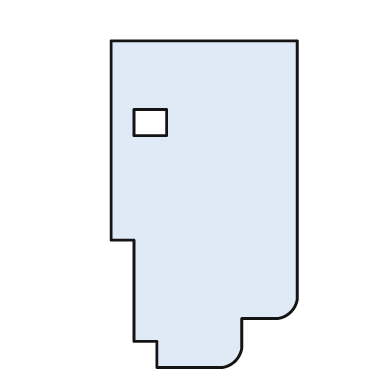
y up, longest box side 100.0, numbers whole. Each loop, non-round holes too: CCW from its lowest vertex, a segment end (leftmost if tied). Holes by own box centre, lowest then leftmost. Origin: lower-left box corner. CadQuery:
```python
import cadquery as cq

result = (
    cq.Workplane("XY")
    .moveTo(14.0, 0.0)
    .lineTo(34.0, 0.0)
    .threePointArc((38.0, 2.0), (40.0, 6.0))
    .lineTo(40.0, 15.0)
    .lineTo(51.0, 15.0)
    .threePointArc((55.0, 17.0), (57.0, 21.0))
    .lineTo(57.0, 100.0)
    .lineTo(0.0, 100.0)
    .lineTo(0.0, 39.0)
    .lineTo(7.0, 39.0)
    .lineTo(7.0, 8.0)
    .lineTo(14.0, 8.0)
    .close()
    .moveTo(7.0, 71.0)
    .lineTo(17.0, 71.0)
    .lineTo(17.0, 79.0)
    .lineTo(7.0, 79.0)
    .close()
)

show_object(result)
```